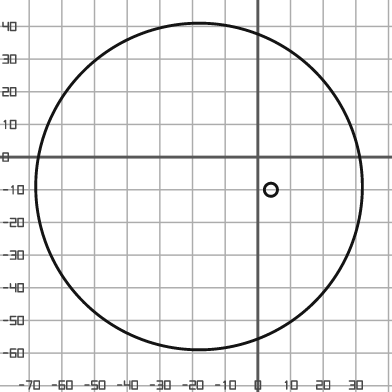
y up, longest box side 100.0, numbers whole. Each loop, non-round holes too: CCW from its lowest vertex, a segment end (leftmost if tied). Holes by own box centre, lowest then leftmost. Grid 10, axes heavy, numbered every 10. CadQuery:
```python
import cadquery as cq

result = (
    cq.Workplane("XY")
    .moveTo(-18.0, -9.0)
    .circle(50.0)
    .moveTo(4.0, -10.0)
    .circle(2.0)
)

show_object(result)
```